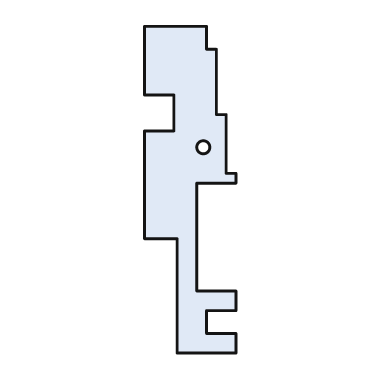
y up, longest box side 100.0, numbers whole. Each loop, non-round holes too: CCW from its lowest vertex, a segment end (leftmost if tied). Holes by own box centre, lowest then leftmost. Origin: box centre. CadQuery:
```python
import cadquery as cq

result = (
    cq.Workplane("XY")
    .moveTo(-4.0, -50.0)
    .lineTo(14.0, -50.0)
    .lineTo(14.0, -44.0)
    .lineTo(5.0, -44.0)
    .lineTo(5.0, -37.0)
    .lineTo(14.0, -37.0)
    .lineTo(14.0, -31.0)
    .lineTo(2.0, -31.0)
    .lineTo(2.0, 2.0)
    .lineTo(14.0, 2.0)
    .lineTo(14.0, 5.0)
    .lineTo(11.0, 5.0)
    .lineTo(11.0, 23.0)
    .lineTo(8.0, 23.0)
    .lineTo(8.0, 43.0)
    .lineTo(5.0, 43.0)
    .lineTo(5.0, 50.0)
    .lineTo(-14.0, 50.0)
    .lineTo(-14.0, 29.0)
    .lineTo(-5.0, 29.0)
    .lineTo(-5.0, 18.0)
    .lineTo(-14.0, 18.0)
    .lineTo(-14.0, -15.0)
    .lineTo(-4.0, -15.0)
    .close()
    .moveTo(4.0, 13.0)
    .circle(2.0)
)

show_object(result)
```